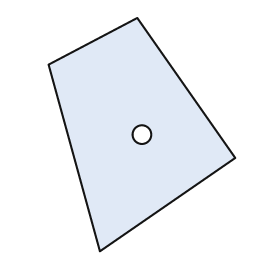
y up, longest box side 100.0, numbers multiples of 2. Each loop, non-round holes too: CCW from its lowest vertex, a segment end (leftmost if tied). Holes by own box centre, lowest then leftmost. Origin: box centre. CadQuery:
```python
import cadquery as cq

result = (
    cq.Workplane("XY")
    .moveTo(-18.0, -50.0)
    .lineTo(40.0, -10.0)
    .lineTo(-2.0, 50.0)
    .lineTo(-40.0, 30.0)
    .close()
    .moveTo(0.0, 0.0)
    .circle(4.0)
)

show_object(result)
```